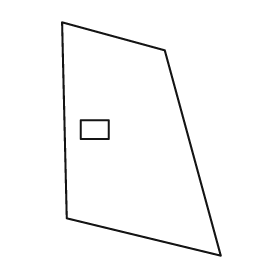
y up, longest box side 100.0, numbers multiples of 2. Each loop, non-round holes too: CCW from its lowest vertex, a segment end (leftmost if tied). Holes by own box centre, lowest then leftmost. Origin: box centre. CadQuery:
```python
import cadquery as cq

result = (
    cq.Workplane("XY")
    .moveTo(34.0, -50.0)
    .lineTo(10.0, 38.0)
    .lineTo(-34.0, 50.0)
    .lineTo(-32.0, -34.0)
    .close()
    .moveTo(-26.0, 0.0)
    .lineTo(-14.0, 0.0)
    .lineTo(-14.0, 8.0)
    .lineTo(-26.0, 8.0)
    .close()
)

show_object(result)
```